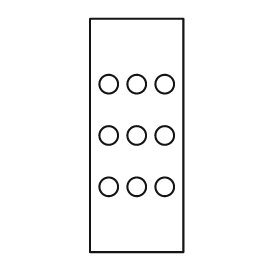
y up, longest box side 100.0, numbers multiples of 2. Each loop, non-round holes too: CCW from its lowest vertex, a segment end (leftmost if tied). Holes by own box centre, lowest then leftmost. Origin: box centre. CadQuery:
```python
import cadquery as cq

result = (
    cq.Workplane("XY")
    .moveTo(-20.0, -50.0)
    .lineTo(20.0, -50.0)
    .lineTo(20.0, 50.0)
    .lineTo(-20.0, 50.0)
    .close()
    .moveTo(-12.0, -22.0)
    .circle(4.0)
    .moveTo(0.0, -22.0)
    .circle(4.0)
    .moveTo(12.0, -22.0)
    .circle(4.0)
    .moveTo(-12.0, 0.0)
    .circle(4.0)
    .moveTo(0.0, 0.0)
    .circle(4.0)
    .moveTo(12.0, 0.0)
    .circle(4.0)
    .moveTo(-12.0, 22.0)
    .circle(4.0)
    .moveTo(0.0, 22.0)
    .circle(4.0)
    .moveTo(12.0, 22.0)
    .circle(4.0)
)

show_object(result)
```